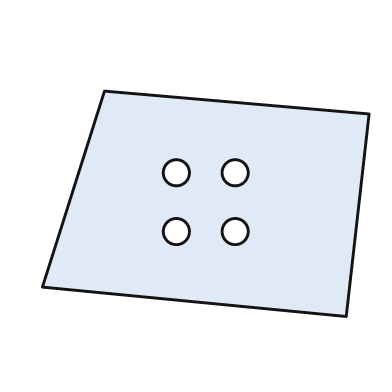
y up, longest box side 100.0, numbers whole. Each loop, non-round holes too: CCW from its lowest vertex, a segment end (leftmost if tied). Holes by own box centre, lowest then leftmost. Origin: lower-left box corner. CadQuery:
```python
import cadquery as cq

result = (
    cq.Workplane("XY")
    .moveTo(93.0, 0.0)
    .lineTo(100.0, 62.0)
    .lineTo(19.0, 69.0)
    .lineTo(0.0, 9.0)
    .close()
    .moveTo(41.0, 26.0)
    .circle(4.0)
    .moveTo(59.0, 26.0)
    .circle(4.0)
    .moveTo(41.0, 44.0)
    .circle(4.0)
    .moveTo(59.0, 44.0)
    .circle(4.0)
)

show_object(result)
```